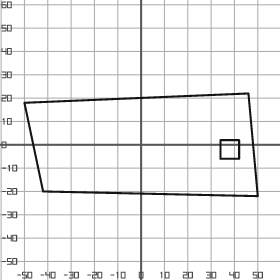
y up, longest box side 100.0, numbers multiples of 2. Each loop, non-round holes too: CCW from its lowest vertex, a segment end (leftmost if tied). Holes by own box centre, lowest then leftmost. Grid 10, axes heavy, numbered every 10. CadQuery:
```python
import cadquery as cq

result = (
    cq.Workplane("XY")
    .moveTo(50.0, -22.0)
    .lineTo(46.0, 22.0)
    .lineTo(-50.0, 18.0)
    .lineTo(-42.0, -20.0)
    .close()
    .moveTo(34.0, -6.0)
    .lineTo(42.0, -6.0)
    .lineTo(42.0, 2.0)
    .lineTo(34.0, 2.0)
    .close()
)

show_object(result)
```